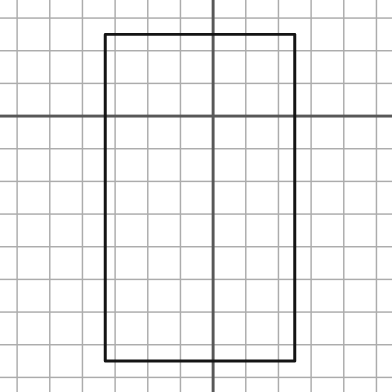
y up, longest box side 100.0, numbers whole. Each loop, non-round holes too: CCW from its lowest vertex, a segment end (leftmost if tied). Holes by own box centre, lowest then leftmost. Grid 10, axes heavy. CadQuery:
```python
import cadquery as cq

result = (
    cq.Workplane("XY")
    .moveTo(-33.0, -75.0)
    .lineTo(25.0, -75.0)
    .lineTo(25.0, 25.0)
    .lineTo(-33.0, 25.0)
    .close()
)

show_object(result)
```